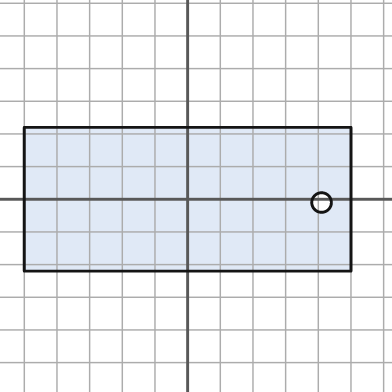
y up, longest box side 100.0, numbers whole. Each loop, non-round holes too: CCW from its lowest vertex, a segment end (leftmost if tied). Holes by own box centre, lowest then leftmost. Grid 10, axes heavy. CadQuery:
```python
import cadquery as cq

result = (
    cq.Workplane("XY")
    .moveTo(-50.0, -22.0)
    .lineTo(50.0, -22.0)
    .lineTo(50.0, 22.0)
    .lineTo(-50.0, 22.0)
    .close()
    .moveTo(41.0, -1.0)
    .circle(3.0)
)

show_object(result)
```